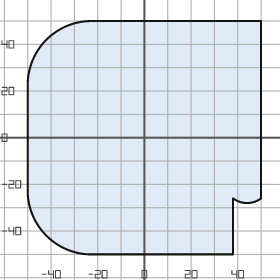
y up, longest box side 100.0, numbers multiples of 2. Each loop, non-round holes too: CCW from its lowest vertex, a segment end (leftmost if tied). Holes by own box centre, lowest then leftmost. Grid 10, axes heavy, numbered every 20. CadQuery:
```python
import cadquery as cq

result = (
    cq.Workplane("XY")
    .moveTo(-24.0, -50.0)
    .lineTo(38.0, -50.0)
    .lineTo(38.0, -26.0)
    .threePointArc((44.0, -28.0), (50.0, -26.0))
    .lineTo(50.0, 50.0)
    .lineTo(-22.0, 50.0)
    .threePointArc((-42.0, 42.0), (-50.0, 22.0))
    .lineTo(-50.0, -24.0)
    .threePointArc((-42.0, -42.0), (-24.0, -50.0))
    .close()
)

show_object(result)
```